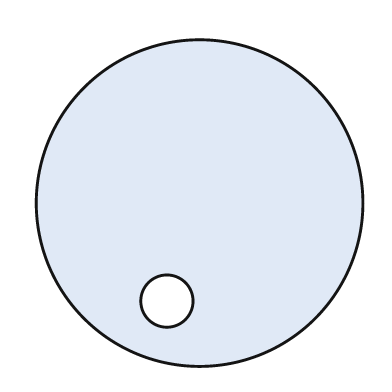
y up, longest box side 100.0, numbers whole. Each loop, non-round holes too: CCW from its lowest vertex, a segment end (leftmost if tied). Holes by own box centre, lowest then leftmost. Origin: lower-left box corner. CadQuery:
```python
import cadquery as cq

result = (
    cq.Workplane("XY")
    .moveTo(50.0, 50.0)
    .circle(50.0)
    .moveTo(40.0, 20.0)
    .circle(8.0)
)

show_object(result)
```